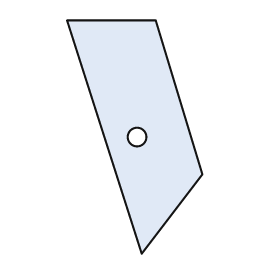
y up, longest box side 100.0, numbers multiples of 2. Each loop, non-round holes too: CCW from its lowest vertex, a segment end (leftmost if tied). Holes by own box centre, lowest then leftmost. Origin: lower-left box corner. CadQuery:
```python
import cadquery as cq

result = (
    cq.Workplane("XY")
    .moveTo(32.0, 0.0)
    .lineTo(58.0, 34.0)
    .lineTo(38.0, 100.0)
    .lineTo(0.0, 100.0)
    .close()
    .moveTo(30.0, 50.0)
    .circle(4.0)
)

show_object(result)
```